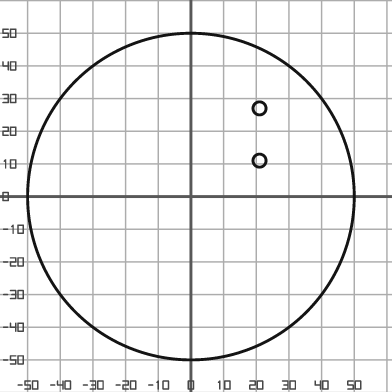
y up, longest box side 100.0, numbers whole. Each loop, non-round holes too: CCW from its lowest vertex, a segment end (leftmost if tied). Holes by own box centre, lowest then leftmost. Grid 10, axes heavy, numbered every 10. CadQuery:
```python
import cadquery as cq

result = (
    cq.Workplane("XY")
    .moveTo(0.0, 0.0)
    .circle(50.0)
    .moveTo(21.0, 11.0)
    .circle(2.0)
    .moveTo(21.0, 27.0)
    .circle(2.0)
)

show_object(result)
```